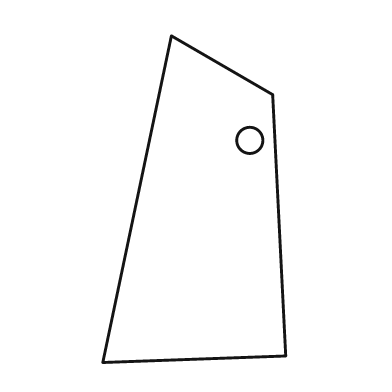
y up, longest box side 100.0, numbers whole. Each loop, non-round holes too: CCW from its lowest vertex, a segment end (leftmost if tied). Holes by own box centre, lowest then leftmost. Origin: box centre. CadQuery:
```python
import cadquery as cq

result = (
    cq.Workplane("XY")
    .moveTo(-28.0, -50.0)
    .lineTo(28.0, -48.0)
    .lineTo(24.0, 32.0)
    .lineTo(-7.0, 50.0)
    .close()
    .moveTo(17.0, 18.0)
    .circle(4.0)
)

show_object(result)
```